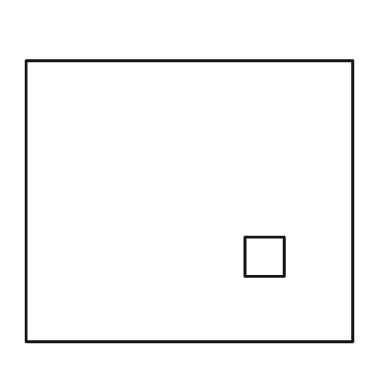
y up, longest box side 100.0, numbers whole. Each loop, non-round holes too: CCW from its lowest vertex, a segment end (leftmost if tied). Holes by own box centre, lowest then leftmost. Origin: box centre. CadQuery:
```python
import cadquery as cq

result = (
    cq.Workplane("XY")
    .moveTo(-50.0, -43.0)
    .lineTo(50.0, -43.0)
    .lineTo(50.0, 43.0)
    .lineTo(-50.0, 43.0)
    .close()
    .moveTo(17.0, -23.0)
    .lineTo(29.0, -23.0)
    .lineTo(29.0, -11.0)
    .lineTo(17.0, -11.0)
    .close()
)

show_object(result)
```